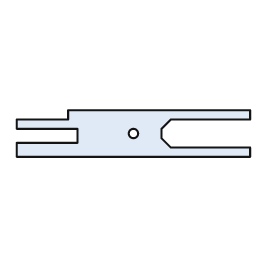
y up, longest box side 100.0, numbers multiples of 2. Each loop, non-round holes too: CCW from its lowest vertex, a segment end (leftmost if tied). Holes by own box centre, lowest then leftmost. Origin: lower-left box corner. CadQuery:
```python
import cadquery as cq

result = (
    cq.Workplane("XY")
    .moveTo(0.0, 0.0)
    .lineTo(100.0, 0.0)
    .lineTo(100.0, 4.0)
    .lineTo(66.0, 4.0)
    .lineTo(62.0, 8.0)
    .lineTo(62.0, 12.0)
    .lineTo(66.0, 16.0)
    .lineTo(100.0, 16.0)
    .lineTo(100.0, 20.0)
    .lineTo(22.0, 20.0)
    .lineTo(22.0, 16.0)
    .lineTo(0.0, 16.0)
    .lineTo(0.0, 12.0)
    .lineTo(26.0, 12.0)
    .lineTo(26.0, 6.0)
    .lineTo(0.0, 6.0)
    .close()
    .moveTo(50.0, 10.0)
    .circle(2.0)
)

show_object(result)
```